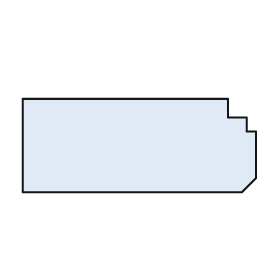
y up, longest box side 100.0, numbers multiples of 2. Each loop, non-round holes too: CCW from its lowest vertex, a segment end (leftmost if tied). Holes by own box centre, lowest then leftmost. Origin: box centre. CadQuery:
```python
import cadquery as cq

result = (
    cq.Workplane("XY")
    .moveTo(-50.0, -20.0)
    .lineTo(44.0, -20.0)
    .lineTo(50.0, -14.0)
    .lineTo(50.0, 6.0)
    .lineTo(46.0, 6.0)
    .lineTo(46.0, 12.0)
    .lineTo(38.0, 12.0)
    .lineTo(38.0, 20.0)
    .lineTo(-50.0, 20.0)
    .close()
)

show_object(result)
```